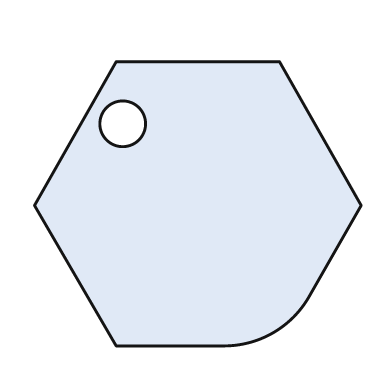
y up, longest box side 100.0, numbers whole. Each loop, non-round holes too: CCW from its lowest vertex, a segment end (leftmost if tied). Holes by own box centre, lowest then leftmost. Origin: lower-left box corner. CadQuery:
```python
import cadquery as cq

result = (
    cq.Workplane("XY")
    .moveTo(25.0, 0.0)
    .lineTo(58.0, 0.0)
    .threePointArc((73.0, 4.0), (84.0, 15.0))
    .lineTo(100.0, 43.0)
    .lineTo(75.0, 87.0)
    .lineTo(25.0, 87.0)
    .lineTo(0.0, 43.0)
    .close()
    .moveTo(27.0, 68.0)
    .circle(7.0)
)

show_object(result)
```